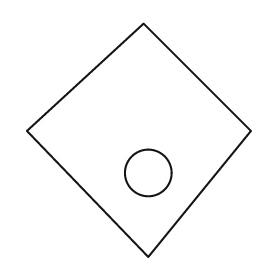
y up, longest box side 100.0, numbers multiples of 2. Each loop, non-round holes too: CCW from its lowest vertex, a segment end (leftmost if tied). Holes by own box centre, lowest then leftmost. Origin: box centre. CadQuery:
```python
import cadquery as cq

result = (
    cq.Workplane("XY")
    .moveTo(4.0, -50.0)
    .lineTo(48.0, 4.0)
    .lineTo(2.0, 50.0)
    .lineTo(-48.0, 4.0)
    .close()
    .moveTo(4.0, -14.0)
    .circle(10.0)
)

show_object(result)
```